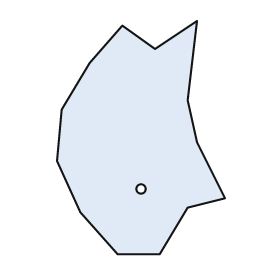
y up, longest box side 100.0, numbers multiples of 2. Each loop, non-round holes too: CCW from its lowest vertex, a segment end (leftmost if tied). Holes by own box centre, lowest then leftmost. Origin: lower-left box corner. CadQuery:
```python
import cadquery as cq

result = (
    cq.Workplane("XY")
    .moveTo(26.0, 0.0)
    .lineTo(44.0, 0.0)
    .lineTo(56.0, 20.0)
    .lineTo(72.0, 24.0)
    .lineTo(60.0, 48.0)
    .lineTo(56.0, 66.0)
    .lineTo(60.0, 100.0)
    .lineTo(42.0, 88.0)
    .lineTo(28.0, 98.0)
    .lineTo(14.0, 82.0)
    .lineTo(2.0, 62.0)
    .lineTo(0.0, 40.0)
    .lineTo(10.0, 18.0)
    .close()
    .moveTo(36.0, 28.0)
    .circle(2.0)
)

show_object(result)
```